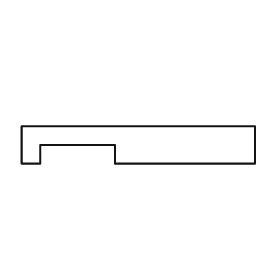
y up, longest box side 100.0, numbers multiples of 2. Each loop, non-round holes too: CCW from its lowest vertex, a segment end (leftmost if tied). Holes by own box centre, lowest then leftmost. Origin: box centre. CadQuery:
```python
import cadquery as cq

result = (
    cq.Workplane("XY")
    .moveTo(-50.0, -8.0)
    .lineTo(-42.0, -8.0)
    .lineTo(-42.0, 0.0)
    .lineTo(-10.0, 0.0)
    .lineTo(-10.0, -8.0)
    .lineTo(50.0, -8.0)
    .lineTo(50.0, 8.0)
    .lineTo(-50.0, 8.0)
    .close()
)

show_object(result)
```